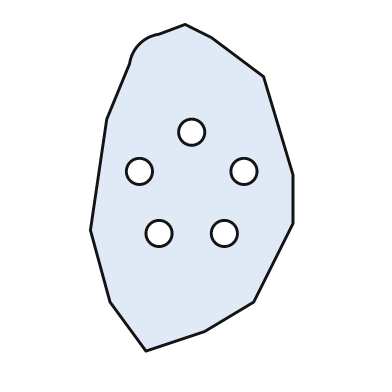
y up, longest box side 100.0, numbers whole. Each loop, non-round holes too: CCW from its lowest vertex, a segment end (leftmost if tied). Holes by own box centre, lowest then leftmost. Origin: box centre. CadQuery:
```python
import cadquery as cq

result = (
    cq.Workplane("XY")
    .moveTo(-14.0, -50.0)
    .lineTo(4.0, -44.0)
    .lineTo(19.0, -35.0)
    .lineTo(31.0, -11.0)
    .lineTo(31.0, 4.0)
    .lineTo(22.0, 34.0)
    .lineTo(6.0, 46.0)
    .lineTo(-2.0, 50.0)
    .lineTo(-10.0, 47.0)
    .threePointArc((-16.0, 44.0), (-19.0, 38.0))
    .lineTo(-26.0, 21.0)
    .lineTo(-31.0, -13.0)
    .lineTo(-25.0, -35.0)
    .close()
    .moveTo(-10.0, -14.0)
    .circle(4.0)
    .moveTo(10.0, -14.0)
    .circle(4.0)
    .moveTo(-16.0, 5.0)
    .circle(4.0)
    .moveTo(16.0, 5.0)
    .circle(4.0)
    .moveTo(0.0, 17.0)
    .circle(4.0)
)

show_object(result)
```